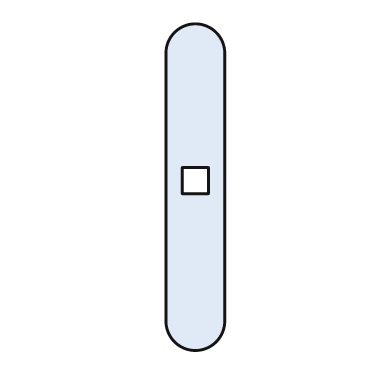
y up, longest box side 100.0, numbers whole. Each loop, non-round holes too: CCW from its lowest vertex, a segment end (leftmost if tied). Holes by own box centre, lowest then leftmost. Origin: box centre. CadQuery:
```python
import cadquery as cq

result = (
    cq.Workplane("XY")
    .moveTo(-9.0, -41.0)
    .threePointArc((0.0, -50.0), (9.0, -41.0))
    .lineTo(9.0, 41.0)
    .threePointArc((0.0, 50.0), (-9.0, 41.0))
    .close()
    .moveTo(-4.0, -2.0)
    .lineTo(4.0, -2.0)
    .lineTo(4.0, 6.0)
    .lineTo(-4.0, 6.0)
    .close()
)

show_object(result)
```